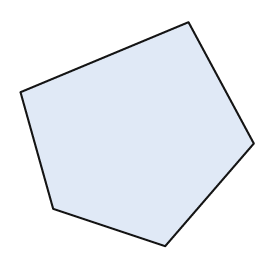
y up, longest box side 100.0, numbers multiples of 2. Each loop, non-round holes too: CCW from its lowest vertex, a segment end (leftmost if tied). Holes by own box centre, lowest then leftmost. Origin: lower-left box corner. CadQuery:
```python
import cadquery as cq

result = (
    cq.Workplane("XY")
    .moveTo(62.0, 0.0)
    .lineTo(100.0, 44.0)
    .lineTo(72.0, 96.0)
    .lineTo(0.0, 66.0)
    .lineTo(14.0, 16.0)
    .close()
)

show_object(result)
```